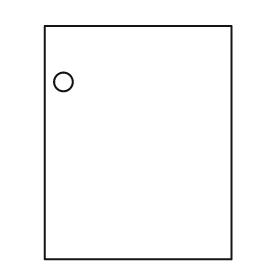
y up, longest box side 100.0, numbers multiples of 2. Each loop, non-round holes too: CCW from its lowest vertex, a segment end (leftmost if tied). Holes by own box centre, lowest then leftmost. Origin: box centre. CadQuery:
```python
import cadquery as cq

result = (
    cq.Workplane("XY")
    .moveTo(-40.0, -50.0)
    .lineTo(40.0, -50.0)
    .lineTo(40.0, 50.0)
    .lineTo(-40.0, 50.0)
    .close()
    .moveTo(-32.0, 26.0)
    .circle(4.0)
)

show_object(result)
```